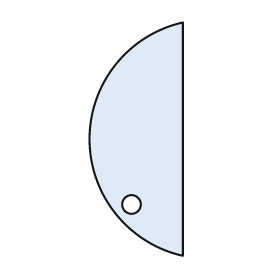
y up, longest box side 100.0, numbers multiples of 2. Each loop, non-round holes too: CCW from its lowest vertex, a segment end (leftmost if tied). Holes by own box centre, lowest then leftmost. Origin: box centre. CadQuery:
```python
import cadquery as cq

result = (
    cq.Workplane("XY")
    .moveTo(20.0, -50.0)
    .lineTo(20.0, 50.0)
    .threePointArc((-20.0, 0.0), (20.0, -50.0))
    .close()
    .moveTo(-2.0, -28.0)
    .circle(4.0)
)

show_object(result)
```